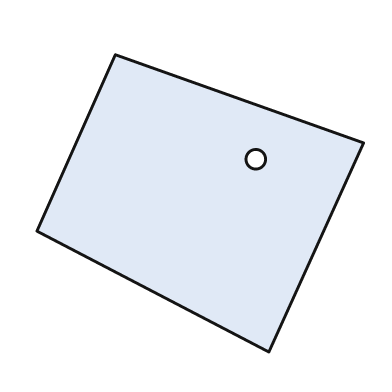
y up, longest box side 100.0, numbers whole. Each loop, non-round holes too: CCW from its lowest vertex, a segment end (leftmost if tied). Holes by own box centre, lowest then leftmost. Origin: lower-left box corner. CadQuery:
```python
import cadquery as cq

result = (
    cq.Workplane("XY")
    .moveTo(71.0, 0.0)
    .lineTo(100.0, 64.0)
    .lineTo(24.0, 91.0)
    .lineTo(0.0, 37.0)
    .close()
    .moveTo(67.0, 59.0)
    .circle(3.0)
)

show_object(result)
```